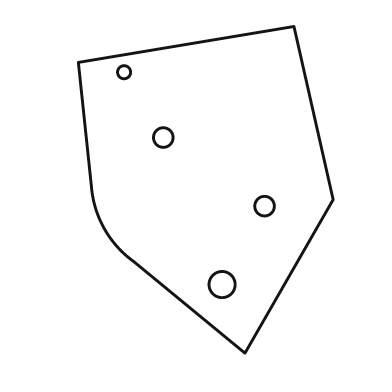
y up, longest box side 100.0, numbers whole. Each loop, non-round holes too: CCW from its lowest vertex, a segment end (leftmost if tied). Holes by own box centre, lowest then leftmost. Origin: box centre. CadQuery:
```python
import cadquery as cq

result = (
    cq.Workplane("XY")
    .moveTo(12.0, -50.0)
    .lineTo(39.0, -3.0)
    .lineTo(27.0, 50.0)
    .lineTo(-39.0, 39.0)
    .lineTo(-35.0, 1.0)
    .threePointArc((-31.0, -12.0), (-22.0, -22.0))
    .close()
    .moveTo(5.0, -29.0)
    .circle(4.0)
    .moveTo(18.0, -5.0)
    .circle(3.0)
    .moveTo(-13.0, 16.0)
    .circle(3.0)
    .moveTo(-25.0, 36.0)
    .circle(2.0)
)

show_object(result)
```